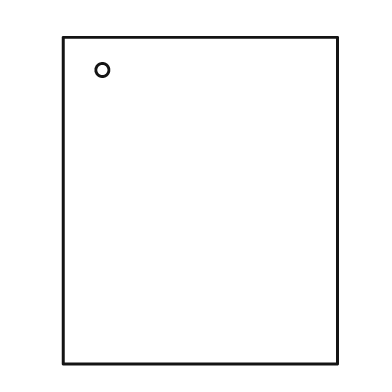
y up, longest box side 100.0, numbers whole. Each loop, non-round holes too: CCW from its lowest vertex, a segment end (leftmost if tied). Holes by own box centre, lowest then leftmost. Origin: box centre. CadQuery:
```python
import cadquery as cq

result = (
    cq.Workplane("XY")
    .moveTo(-42.0, -50.0)
    .lineTo(42.0, -50.0)
    .lineTo(42.0, 50.0)
    .lineTo(-42.0, 50.0)
    .close()
    .moveTo(-30.0, 40.0)
    .circle(2.0)
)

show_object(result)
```